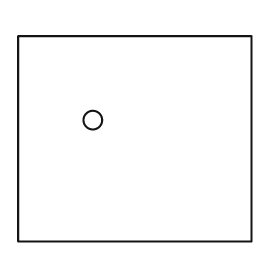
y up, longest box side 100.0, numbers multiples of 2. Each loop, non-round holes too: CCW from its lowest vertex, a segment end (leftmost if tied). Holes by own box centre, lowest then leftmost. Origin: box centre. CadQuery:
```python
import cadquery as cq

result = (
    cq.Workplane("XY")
    .moveTo(-50.0, -44.0)
    .lineTo(50.0, -44.0)
    .lineTo(50.0, 44.0)
    .lineTo(-50.0, 44.0)
    .close()
    .moveTo(-18.0, 8.0)
    .circle(4.0)
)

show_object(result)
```